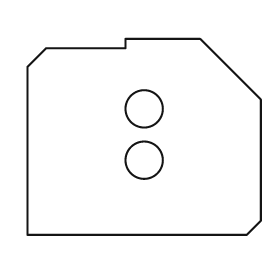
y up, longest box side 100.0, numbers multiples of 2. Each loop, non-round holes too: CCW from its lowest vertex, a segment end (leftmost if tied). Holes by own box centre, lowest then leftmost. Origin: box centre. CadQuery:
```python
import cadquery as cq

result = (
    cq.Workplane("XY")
    .moveTo(-50.0, -42.0)
    .lineTo(44.0, -42.0)
    .lineTo(50.0, -36.0)
    .lineTo(50.0, 16.0)
    .lineTo(24.0, 42.0)
    .lineTo(-8.0, 42.0)
    .lineTo(-8.0, 38.0)
    .lineTo(-42.0, 38.0)
    .lineTo(-50.0, 30.0)
    .close()
    .moveTo(0.0, -10.0)
    .circle(8.0)
    .moveTo(0.0, 12.0)
    .circle(8.0)
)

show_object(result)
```